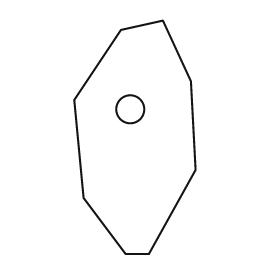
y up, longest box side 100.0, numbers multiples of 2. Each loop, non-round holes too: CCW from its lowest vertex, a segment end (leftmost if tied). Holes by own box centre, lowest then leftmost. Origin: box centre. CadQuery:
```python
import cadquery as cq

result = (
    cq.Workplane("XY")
    .moveTo(-4.0, -50.0)
    .lineTo(6.0, -50.0)
    .lineTo(26.0, -14.0)
    .lineTo(24.0, 24.0)
    .lineTo(12.0, 50.0)
    .lineTo(-6.0, 46.0)
    .lineTo(-26.0, 16.0)
    .lineTo(-22.0, -26.0)
    .close()
    .moveTo(-2.0, 12.0)
    .circle(6.0)
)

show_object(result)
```